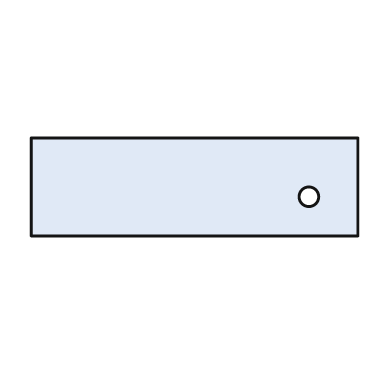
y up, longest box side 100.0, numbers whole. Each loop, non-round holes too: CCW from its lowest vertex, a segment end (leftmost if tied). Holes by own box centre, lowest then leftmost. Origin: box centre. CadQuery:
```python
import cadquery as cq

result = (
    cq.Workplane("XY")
    .moveTo(-50.0, -15.0)
    .lineTo(50.0, -15.0)
    .lineTo(50.0, 15.0)
    .lineTo(-50.0, 15.0)
    .close()
    .moveTo(35.0, -3.0)
    .circle(3.0)
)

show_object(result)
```